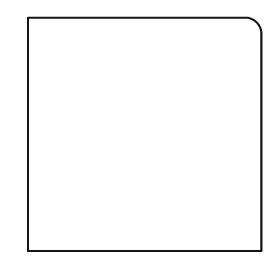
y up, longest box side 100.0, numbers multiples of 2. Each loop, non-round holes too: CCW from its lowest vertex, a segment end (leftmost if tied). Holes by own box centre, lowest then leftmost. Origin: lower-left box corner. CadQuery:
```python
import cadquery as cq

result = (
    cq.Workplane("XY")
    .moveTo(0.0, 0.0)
    .lineTo(100.0, 0.0)
    .lineTo(100.0, 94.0)
    .threePointArc((98.0, 98.0), (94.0, 100.0))
    .lineTo(0.0, 100.0)
    .close()
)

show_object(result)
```